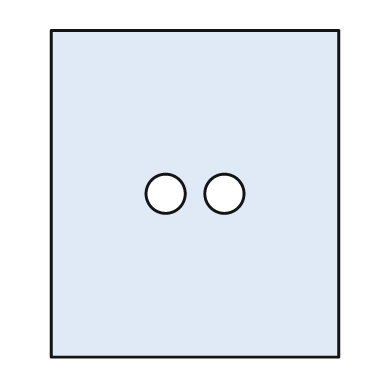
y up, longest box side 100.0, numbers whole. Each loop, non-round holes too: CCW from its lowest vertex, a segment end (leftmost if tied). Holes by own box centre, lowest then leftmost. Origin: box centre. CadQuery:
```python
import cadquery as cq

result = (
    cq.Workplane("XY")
    .moveTo(-44.0, -50.0)
    .lineTo(44.0, -50.0)
    .lineTo(44.0, 50.0)
    .lineTo(-44.0, 50.0)
    .close()
    .moveTo(-9.0, 0.0)
    .circle(6.0)
    .moveTo(9.0, 0.0)
    .circle(6.0)
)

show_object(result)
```